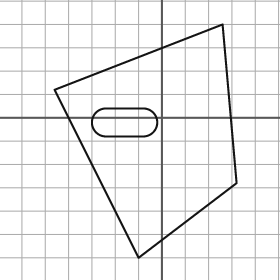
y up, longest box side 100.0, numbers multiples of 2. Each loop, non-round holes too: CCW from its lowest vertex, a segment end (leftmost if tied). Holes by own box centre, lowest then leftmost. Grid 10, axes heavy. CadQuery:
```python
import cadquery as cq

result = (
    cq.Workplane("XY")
    .moveTo(-10.0, -60.0)
    .lineTo(32.0, -28.0)
    .lineTo(26.0, 40.0)
    .lineTo(-46.0, 12.0)
    .close()
    .moveTo(-24.0, -8.0)
    .lineTo(-8.0, -8.0)
    .threePointArc((-2.0, -2.0), (-8.0, 4.0))
    .lineTo(-24.0, 4.0)
    .threePointArc((-30.0, -2.0), (-24.0, -8.0))
    .close()
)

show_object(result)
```